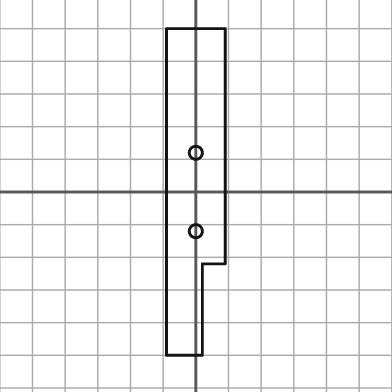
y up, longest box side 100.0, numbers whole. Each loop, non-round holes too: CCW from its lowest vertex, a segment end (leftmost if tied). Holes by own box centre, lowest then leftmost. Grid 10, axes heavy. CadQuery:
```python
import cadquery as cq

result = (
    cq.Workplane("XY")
    .moveTo(-9.0, -50.0)
    .lineTo(2.0, -50.0)
    .lineTo(2.0, -22.0)
    .lineTo(9.0, -22.0)
    .lineTo(9.0, 50.0)
    .lineTo(-9.0, 50.0)
    .close()
    .moveTo(0.0, -12.0)
    .circle(2.0)
    .moveTo(0.0, 12.0)
    .circle(2.0)
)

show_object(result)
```